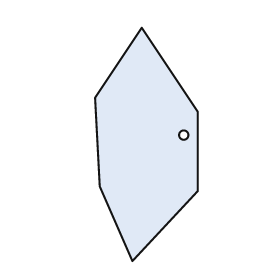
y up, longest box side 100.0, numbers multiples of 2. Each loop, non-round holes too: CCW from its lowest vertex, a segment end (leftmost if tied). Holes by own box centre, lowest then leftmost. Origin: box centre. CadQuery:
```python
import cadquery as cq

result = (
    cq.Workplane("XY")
    .moveTo(-6.0, -50.0)
    .lineTo(22.0, -20.0)
    .lineTo(22.0, 14.0)
    .lineTo(-2.0, 50.0)
    .lineTo(-22.0, 20.0)
    .lineTo(-20.0, -18.0)
    .close()
    .moveTo(16.0, 4.0)
    .circle(2.0)
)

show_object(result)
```